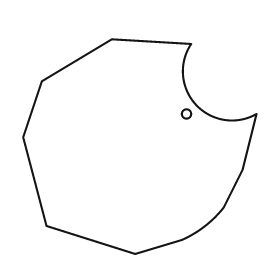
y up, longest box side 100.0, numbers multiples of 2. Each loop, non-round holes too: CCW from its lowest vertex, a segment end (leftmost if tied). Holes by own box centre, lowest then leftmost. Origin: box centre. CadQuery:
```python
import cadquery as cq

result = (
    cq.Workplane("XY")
    .moveTo(-2.0, -46.0)
    .lineTo(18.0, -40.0)
    .threePointArc((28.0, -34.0), (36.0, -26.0))
    .lineTo(44.0, -10.0)
    .lineTo(50.0, 14.0)
    .threePointArc((24.0, 18.0), (22.0, 44.0))
    .lineTo(-12.0, 46.0)
    .lineTo(-42.0, 28.0)
    .lineTo(-50.0, 4.0)
    .lineTo(-40.0, -34.0)
    .close()
    .moveTo(20.0, 14.0)
    .circle(2.0)
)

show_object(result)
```